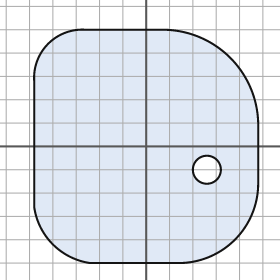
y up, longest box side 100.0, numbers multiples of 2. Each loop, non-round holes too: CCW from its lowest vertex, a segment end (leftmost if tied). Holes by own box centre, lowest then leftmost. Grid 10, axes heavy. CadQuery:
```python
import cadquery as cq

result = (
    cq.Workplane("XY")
    .moveTo(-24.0, -50.0)
    .lineTo(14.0, -50.0)
    .threePointArc((38.0, -40.0), (48.0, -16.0))
    .lineTo(48.0, 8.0)
    .threePointArc((36.0, 38.0), (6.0, 50.0))
    .lineTo(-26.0, 50.0)
    .threePointArc((-42.0, 44.0), (-48.0, 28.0))
    .lineTo(-48.0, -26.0)
    .threePointArc((-40.0, -42.0), (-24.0, -50.0))
    .close()
    .moveTo(26.0, -10.0)
    .circle(6.0)
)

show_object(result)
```